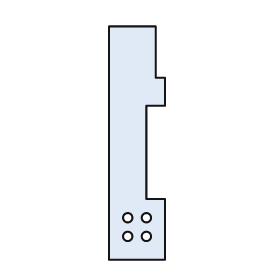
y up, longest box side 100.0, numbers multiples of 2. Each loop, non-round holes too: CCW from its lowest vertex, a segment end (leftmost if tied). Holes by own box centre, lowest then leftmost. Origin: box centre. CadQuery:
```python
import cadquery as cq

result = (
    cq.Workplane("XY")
    .moveTo(-12.0, -50.0)
    .lineTo(12.0, -50.0)
    .lineTo(12.0, -24.0)
    .lineTo(4.0, -24.0)
    .lineTo(4.0, 16.0)
    .lineTo(12.0, 16.0)
    .lineTo(12.0, 28.0)
    .lineTo(8.0, 28.0)
    .lineTo(8.0, 50.0)
    .lineTo(-12.0, 50.0)
    .close()
    .moveTo(-4.0, -40.0)
    .circle(2.0)
    .moveTo(4.0, -40.0)
    .circle(2.0)
    .moveTo(-4.0, -32.0)
    .circle(2.0)
    .moveTo(4.0, -32.0)
    .circle(2.0)
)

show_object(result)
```